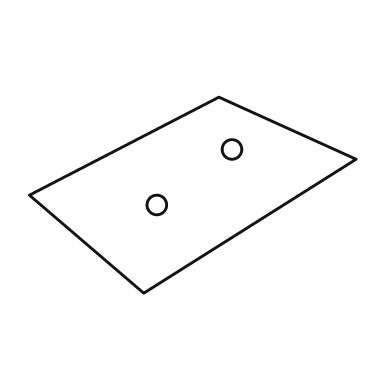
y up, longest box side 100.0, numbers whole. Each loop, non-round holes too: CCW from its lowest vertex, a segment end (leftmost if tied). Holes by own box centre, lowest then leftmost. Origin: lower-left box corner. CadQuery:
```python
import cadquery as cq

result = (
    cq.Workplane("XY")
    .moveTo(35.0, 0.0)
    .lineTo(100.0, 41.0)
    .lineTo(58.0, 60.0)
    .lineTo(0.0, 30.0)
    .close()
    .moveTo(39.0, 27.0)
    .circle(3.0)
    .moveTo(62.0, 44.0)
    .circle(3.0)
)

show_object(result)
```